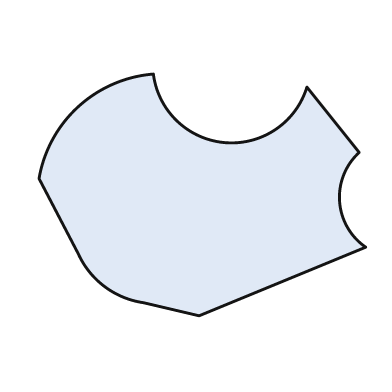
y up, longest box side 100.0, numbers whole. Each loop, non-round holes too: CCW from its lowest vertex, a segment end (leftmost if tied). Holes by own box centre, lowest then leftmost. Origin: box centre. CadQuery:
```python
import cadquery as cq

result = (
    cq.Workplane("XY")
    .moveTo(-1.0, -37.0)
    .lineTo(50.0, -16.0)
    .threePointArc((42.0, -2.0), (48.0, 13.0))
    .lineTo(32.0, 33.0)
    .threePointArc((7.0, 16.0), (-15.0, 37.0))
    .threePointArc((-38.0, 27.0), (-50.0, 5.0))
    .lineTo(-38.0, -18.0)
    .threePointArc((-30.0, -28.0), (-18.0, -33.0))
    .close()
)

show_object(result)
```